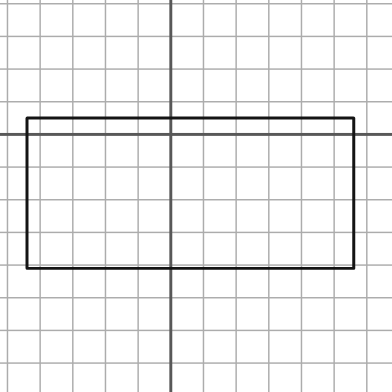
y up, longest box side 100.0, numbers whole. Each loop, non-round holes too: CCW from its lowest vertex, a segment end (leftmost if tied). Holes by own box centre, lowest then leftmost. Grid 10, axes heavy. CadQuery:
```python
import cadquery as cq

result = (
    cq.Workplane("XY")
    .moveTo(-44.0, -41.0)
    .lineTo(56.0, -41.0)
    .lineTo(56.0, 5.0)
    .lineTo(-44.0, 5.0)
    .close()
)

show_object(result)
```